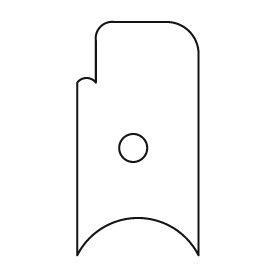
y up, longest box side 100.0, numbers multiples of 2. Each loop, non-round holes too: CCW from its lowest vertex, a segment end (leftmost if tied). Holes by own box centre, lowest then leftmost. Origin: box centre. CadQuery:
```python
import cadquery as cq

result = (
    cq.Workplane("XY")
    .moveTo(-26.0, -50.0)
    .threePointArc((0.0, -34.0), (26.0, -50.0))
    .lineTo(26.0, 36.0)
    .threePointArc((22.0, 46.0), (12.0, 50.0))
    .lineTo(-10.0, 50.0)
    .threePointArc((-16.0, 48.0), (-18.0, 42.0))
    .lineTo(-18.0, 24.0)
    .threePointArc((-22.0, 26.0), (-26.0, 24.0))
    .close()
    .moveTo(-2.0, -4.0)
    .circle(6.0)
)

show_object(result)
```